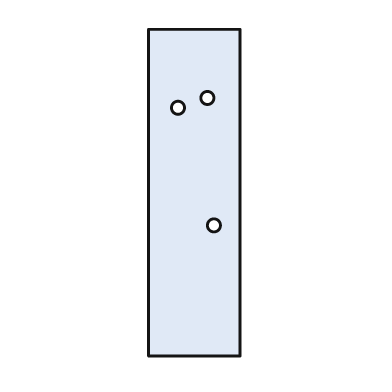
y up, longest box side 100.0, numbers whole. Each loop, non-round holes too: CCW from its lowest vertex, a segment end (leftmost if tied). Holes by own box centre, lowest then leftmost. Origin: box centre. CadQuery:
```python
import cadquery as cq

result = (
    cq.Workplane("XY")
    .moveTo(-14.0, -50.0)
    .lineTo(14.0, -50.0)
    .lineTo(14.0, 50.0)
    .lineTo(-14.0, 50.0)
    .close()
    .moveTo(6.0, -10.0)
    .circle(2.0)
    .moveTo(-5.0, 26.0)
    .circle(2.0)
    .moveTo(4.0, 29.0)
    .circle(2.0)
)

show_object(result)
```